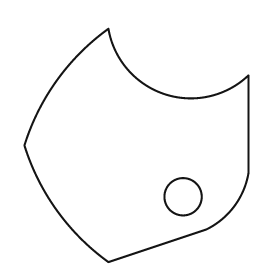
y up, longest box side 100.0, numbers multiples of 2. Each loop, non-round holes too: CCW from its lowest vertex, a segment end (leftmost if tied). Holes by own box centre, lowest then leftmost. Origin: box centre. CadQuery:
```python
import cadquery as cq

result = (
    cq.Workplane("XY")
    .moveTo(-12.0, -50.0)
    .lineTo(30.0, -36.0)
    .threePointArc((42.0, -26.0), (48.0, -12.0))
    .lineTo(48.0, 30.0)
    .threePointArc((12.0, 22.0), (-12.0, 50.0))
    .threePointArc((-34.0, 28.0), (-48.0, 0.0))
    .threePointArc((-34.0, -28.0), (-12.0, -50.0))
    .close()
    .moveTo(20.0, -22.0)
    .circle(8.0)
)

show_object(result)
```